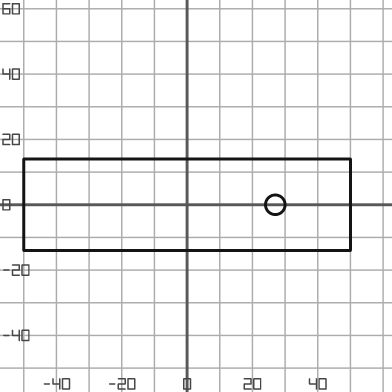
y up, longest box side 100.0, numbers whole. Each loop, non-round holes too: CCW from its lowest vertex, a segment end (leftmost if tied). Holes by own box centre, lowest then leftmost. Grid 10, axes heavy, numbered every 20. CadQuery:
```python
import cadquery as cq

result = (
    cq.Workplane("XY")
    .moveTo(-50.0, -14.0)
    .lineTo(50.0, -14.0)
    .lineTo(50.0, 14.0)
    .lineTo(-50.0, 14.0)
    .close()
    .moveTo(27.0, 0.0)
    .circle(3.0)
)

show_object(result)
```